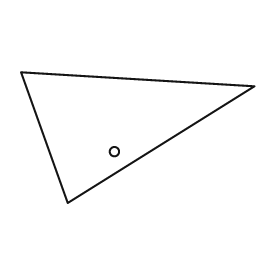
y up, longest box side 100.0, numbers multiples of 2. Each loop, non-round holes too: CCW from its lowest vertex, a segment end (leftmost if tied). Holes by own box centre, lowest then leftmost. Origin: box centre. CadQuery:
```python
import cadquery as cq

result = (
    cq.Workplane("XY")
    .moveTo(-30.0, -28.0)
    .lineTo(50.0, 22.0)
    .lineTo(-50.0, 28.0)
    .close()
    .moveTo(-10.0, -6.0)
    .circle(2.0)
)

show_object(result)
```